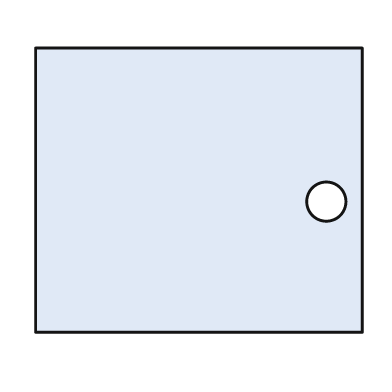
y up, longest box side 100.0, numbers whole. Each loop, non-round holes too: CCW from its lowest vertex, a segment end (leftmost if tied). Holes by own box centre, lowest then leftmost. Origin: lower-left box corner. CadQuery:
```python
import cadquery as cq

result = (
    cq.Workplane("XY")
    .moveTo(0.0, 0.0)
    .lineTo(100.0, 0.0)
    .lineTo(100.0, 87.0)
    .lineTo(0.0, 87.0)
    .close()
    .moveTo(89.0, 40.0)
    .circle(6.0)
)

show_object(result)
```